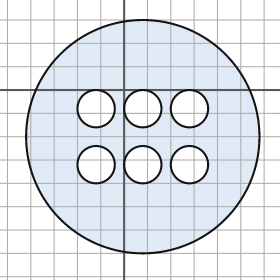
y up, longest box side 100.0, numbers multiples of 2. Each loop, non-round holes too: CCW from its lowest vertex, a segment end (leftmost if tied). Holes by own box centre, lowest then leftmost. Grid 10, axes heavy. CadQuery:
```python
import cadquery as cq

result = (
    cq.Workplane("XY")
    .moveTo(8.0, -20.0)
    .circle(50.0)
    .moveTo(-12.0, -32.0)
    .circle(8.0)
    .moveTo(8.0, -32.0)
    .circle(8.0)
    .moveTo(28.0, -32.0)
    .circle(8.0)
    .moveTo(-12.0, -8.0)
    .circle(8.0)
    .moveTo(8.0, -8.0)
    .circle(8.0)
    .moveTo(28.0, -8.0)
    .circle(8.0)
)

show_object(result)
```